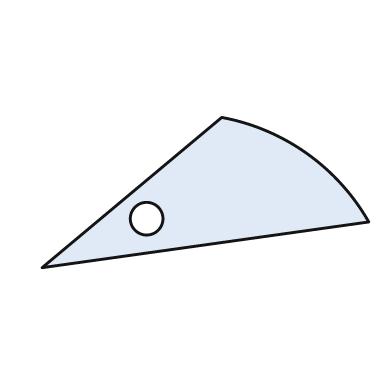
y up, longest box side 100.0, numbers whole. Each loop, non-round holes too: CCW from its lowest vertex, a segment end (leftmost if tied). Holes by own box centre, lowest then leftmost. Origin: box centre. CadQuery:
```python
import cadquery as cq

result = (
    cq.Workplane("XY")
    .moveTo(-50.0, -23.0)
    .lineTo(50.0, -9.0)
    .threePointArc((31.0, 12.0), (5.0, 23.0))
    .close()
    .moveTo(-18.0, -8.0)
    .circle(5.0)
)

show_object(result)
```